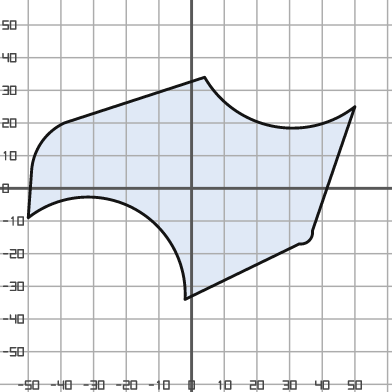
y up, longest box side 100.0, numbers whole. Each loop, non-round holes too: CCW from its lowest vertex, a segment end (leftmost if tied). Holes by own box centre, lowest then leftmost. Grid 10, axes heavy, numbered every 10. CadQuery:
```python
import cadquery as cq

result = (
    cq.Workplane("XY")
    .moveTo(-2.0, -34.0)
    .lineTo(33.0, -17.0)
    .threePointArc((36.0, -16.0), (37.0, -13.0))
    .lineTo(50.0, 25.0)
    .threePointArc((25.0, 19.0), (4.0, 34.0))
    .lineTo(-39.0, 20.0)
    .threePointArc((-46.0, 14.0), (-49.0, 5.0))
    .lineTo(-50.0, -9.0)
    .threePointArc((-18.0, -6.0), (-2.0, -34.0))
    .close()
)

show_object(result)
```